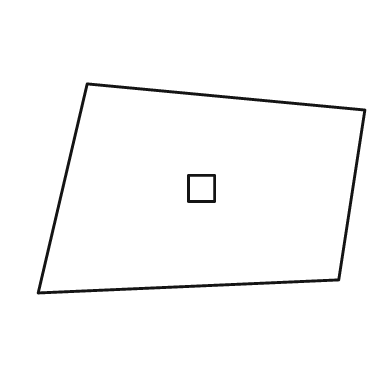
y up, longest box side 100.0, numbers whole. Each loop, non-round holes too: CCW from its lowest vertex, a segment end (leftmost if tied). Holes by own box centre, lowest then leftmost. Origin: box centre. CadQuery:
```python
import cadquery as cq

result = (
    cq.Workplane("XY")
    .moveTo(-50.0, -32.0)
    .lineTo(42.0, -28.0)
    .lineTo(50.0, 24.0)
    .lineTo(-35.0, 32.0)
    .close()
    .moveTo(-4.0, -4.0)
    .lineTo(4.0, -4.0)
    .lineTo(4.0, 4.0)
    .lineTo(-4.0, 4.0)
    .close()
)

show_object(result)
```